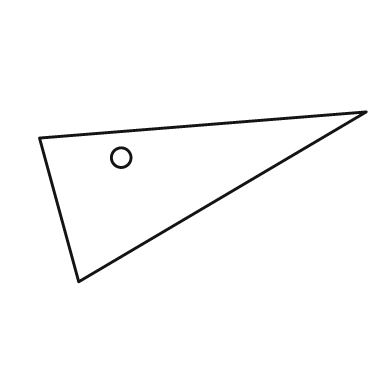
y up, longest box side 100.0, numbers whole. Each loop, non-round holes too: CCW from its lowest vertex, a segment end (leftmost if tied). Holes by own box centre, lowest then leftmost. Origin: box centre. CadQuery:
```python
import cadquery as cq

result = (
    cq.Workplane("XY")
    .moveTo(-38.0, -26.0)
    .lineTo(50.0, 26.0)
    .lineTo(-50.0, 18.0)
    .close()
    .moveTo(-25.0, 12.0)
    .circle(3.0)
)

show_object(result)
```